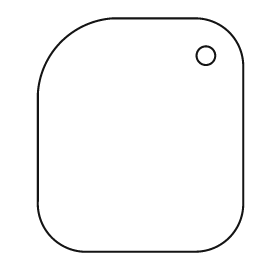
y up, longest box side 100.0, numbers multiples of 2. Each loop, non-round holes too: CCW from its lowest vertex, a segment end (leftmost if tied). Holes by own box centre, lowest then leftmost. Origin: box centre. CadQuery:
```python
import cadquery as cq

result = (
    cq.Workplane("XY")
    .moveTo(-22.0, -50.0)
    .lineTo(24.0, -50.0)
    .threePointArc((38.0, -44.0), (44.0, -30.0))
    .lineTo(44.0, 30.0)
    .threePointArc((38.0, 44.0), (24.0, 50.0))
    .lineTo(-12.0, 50.0)
    .threePointArc((-34.0, 40.0), (-44.0, 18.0))
    .lineTo(-44.0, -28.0)
    .threePointArc((-38.0, -44.0), (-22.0, -50.0))
    .close()
    .moveTo(28.0, 34.0)
    .circle(4.0)
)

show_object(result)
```